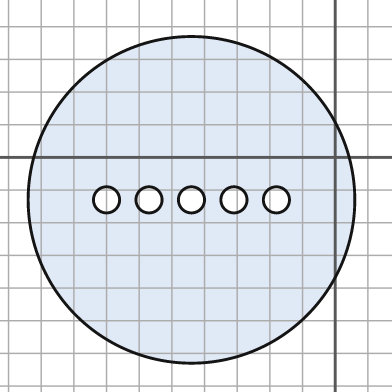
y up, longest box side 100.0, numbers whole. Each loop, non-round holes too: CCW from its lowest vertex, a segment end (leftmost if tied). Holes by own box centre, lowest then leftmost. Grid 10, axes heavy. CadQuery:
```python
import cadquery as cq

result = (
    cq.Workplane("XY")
    .moveTo(-44.0, -13.0)
    .circle(50.0)
    .moveTo(-70.0, -13.0)
    .circle(4.0)
    .moveTo(-57.0, -13.0)
    .circle(4.0)
    .moveTo(-44.0, -13.0)
    .circle(4.0)
    .moveTo(-31.0, -13.0)
    .circle(4.0)
    .moveTo(-18.0, -13.0)
    .circle(4.0)
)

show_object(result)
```